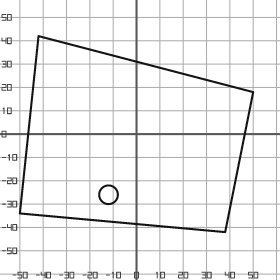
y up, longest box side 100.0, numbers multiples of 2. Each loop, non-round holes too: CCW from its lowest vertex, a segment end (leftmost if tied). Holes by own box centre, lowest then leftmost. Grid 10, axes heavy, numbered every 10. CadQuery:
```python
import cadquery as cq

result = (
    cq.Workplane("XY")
    .moveTo(38.0, -42.0)
    .lineTo(50.0, 18.0)
    .lineTo(-42.0, 42.0)
    .lineTo(-50.0, -34.0)
    .close()
    .moveTo(-12.0, -26.0)
    .circle(4.0)
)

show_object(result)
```